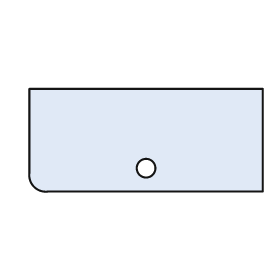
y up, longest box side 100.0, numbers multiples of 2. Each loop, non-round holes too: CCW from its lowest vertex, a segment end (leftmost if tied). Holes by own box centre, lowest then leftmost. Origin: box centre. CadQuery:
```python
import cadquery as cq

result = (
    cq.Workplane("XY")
    .moveTo(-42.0, -22.0)
    .lineTo(50.0, -22.0)
    .lineTo(50.0, 22.0)
    .lineTo(-50.0, 22.0)
    .lineTo(-50.0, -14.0)
    .threePointArc((-48.0, -20.0), (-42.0, -22.0))
    .close()
    .moveTo(0.0, -12.0)
    .circle(4.0)
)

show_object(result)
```